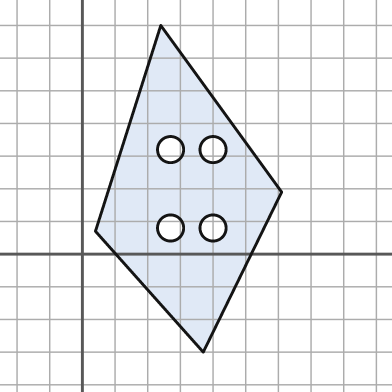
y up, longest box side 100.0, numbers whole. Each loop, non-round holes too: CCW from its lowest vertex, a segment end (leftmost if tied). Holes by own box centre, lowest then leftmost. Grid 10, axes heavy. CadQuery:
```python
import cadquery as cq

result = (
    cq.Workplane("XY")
    .moveTo(37.0, -30.0)
    .lineTo(61.0, 19.0)
    .lineTo(24.0, 70.0)
    .lineTo(4.0, 7.0)
    .close()
    .moveTo(27.0, 8.0)
    .circle(4.0)
    .moveTo(40.0, 8.0)
    .circle(4.0)
    .moveTo(27.0, 32.0)
    .circle(4.0)
    .moveTo(40.0, 32.0)
    .circle(4.0)
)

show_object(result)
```